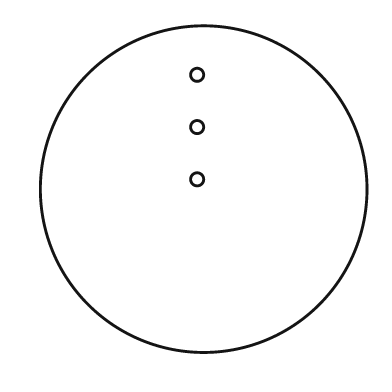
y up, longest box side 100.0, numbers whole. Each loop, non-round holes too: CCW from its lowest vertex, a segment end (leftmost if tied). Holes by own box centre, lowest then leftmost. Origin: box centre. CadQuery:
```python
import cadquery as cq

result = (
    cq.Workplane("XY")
    .moveTo(0.0, 0.0)
    .circle(50.0)
    .moveTo(-2.0, 3.0)
    .circle(2.0)
    .moveTo(-2.0, 19.0)
    .circle(2.0)
    .moveTo(-2.0, 35.0)
    .circle(2.0)
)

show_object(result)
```